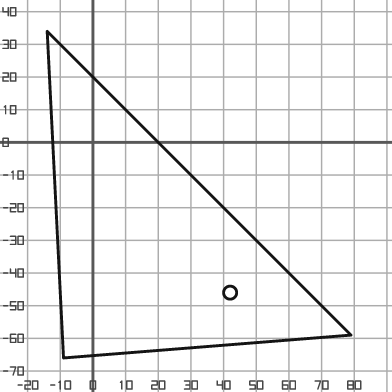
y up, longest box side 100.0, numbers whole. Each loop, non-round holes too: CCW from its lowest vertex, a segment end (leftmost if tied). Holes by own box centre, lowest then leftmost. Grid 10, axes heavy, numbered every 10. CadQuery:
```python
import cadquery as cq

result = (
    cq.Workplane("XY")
    .moveTo(-9.0, -66.0)
    .lineTo(79.0, -59.0)
    .lineTo(-14.0, 34.0)
    .close()
    .moveTo(42.0, -46.0)
    .circle(2.0)
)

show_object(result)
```